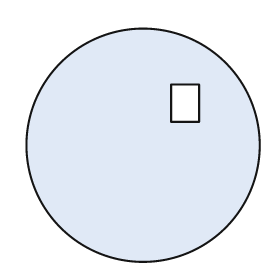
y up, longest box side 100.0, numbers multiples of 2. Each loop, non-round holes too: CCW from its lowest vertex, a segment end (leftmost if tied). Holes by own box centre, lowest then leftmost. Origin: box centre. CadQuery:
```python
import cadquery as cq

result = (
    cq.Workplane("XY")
    .moveTo(0.0, 0.0)
    .circle(50.0)
    .moveTo(12.0, 10.0)
    .lineTo(24.0, 10.0)
    .lineTo(24.0, 26.0)
    .lineTo(12.0, 26.0)
    .close()
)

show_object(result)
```